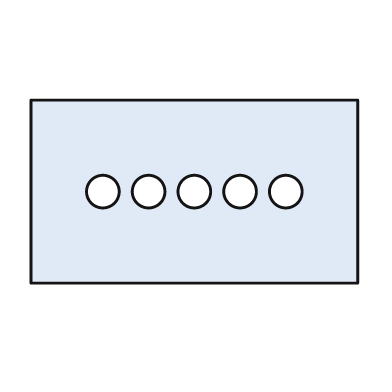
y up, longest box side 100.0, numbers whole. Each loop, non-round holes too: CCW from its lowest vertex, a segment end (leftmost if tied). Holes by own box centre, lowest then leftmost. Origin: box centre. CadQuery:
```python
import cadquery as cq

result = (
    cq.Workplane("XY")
    .moveTo(-50.0, -28.0)
    .lineTo(50.0, -28.0)
    .lineTo(50.0, 28.0)
    .lineTo(-50.0, 28.0)
    .close()
    .moveTo(-28.0, 0.0)
    .circle(5.0)
    .moveTo(-14.0, 0.0)
    .circle(5.0)
    .moveTo(0.0, 0.0)
    .circle(5.0)
    .moveTo(14.0, 0.0)
    .circle(5.0)
    .moveTo(28.0, 0.0)
    .circle(5.0)
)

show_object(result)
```